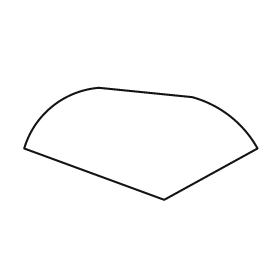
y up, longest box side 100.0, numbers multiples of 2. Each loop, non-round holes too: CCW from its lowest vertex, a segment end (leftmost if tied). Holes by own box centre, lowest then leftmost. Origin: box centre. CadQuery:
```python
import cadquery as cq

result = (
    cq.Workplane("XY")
    .moveTo(10.0, -24.0)
    .lineTo(50.0, -2.0)
    .threePointArc((38.0, 12.0), (22.0, 20.0))
    .lineTo(-18.0, 24.0)
    .threePointArc((-38.0, 16.0), (-50.0, -2.0))
    .close()
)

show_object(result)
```